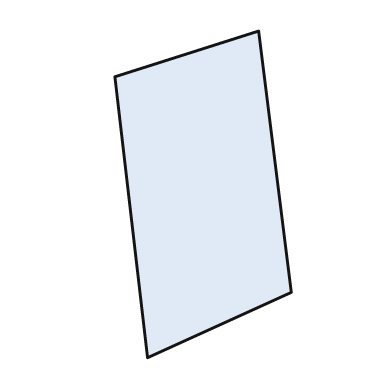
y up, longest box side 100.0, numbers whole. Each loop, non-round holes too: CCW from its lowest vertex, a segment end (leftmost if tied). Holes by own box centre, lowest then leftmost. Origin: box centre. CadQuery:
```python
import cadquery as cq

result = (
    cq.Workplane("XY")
    .moveTo(-17.0, -50.0)
    .lineTo(27.0, -30.0)
    .lineTo(17.0, 50.0)
    .lineTo(-27.0, 36.0)
    .close()
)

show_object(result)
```